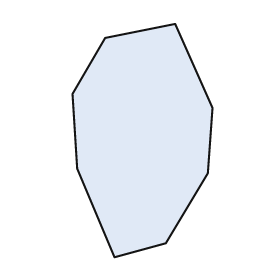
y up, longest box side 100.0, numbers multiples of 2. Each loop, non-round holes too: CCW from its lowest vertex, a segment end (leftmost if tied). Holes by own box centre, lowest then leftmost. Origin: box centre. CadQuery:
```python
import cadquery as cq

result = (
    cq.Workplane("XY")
    .moveTo(-12.0, -50.0)
    .lineTo(10.0, -44.0)
    .lineTo(28.0, -14.0)
    .lineTo(30.0, 14.0)
    .lineTo(14.0, 50.0)
    .lineTo(-16.0, 44.0)
    .lineTo(-30.0, 20.0)
    .lineTo(-28.0, -12.0)
    .close()
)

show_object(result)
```